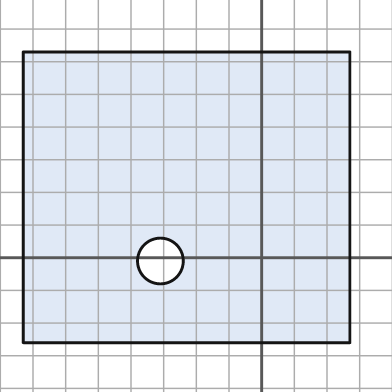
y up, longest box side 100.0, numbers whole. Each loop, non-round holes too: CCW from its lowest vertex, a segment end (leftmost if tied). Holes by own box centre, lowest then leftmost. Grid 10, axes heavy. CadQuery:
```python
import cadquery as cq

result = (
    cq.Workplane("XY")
    .moveTo(-73.0, -26.0)
    .lineTo(27.0, -26.0)
    .lineTo(27.0, 63.0)
    .lineTo(-73.0, 63.0)
    .close()
    .moveTo(-31.0, -1.0)
    .circle(7.0)
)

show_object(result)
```